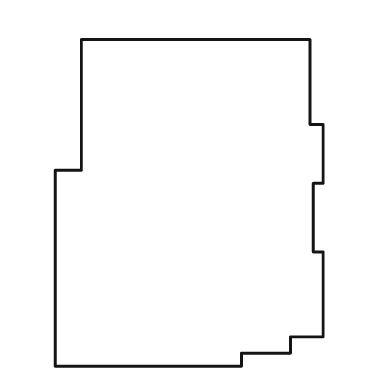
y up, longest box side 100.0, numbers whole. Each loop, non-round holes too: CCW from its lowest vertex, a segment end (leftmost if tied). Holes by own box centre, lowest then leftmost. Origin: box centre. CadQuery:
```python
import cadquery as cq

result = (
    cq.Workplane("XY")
    .moveTo(-41.0, -50.0)
    .lineTo(16.0, -50.0)
    .lineTo(16.0, -46.0)
    .lineTo(31.0, -46.0)
    .lineTo(31.0, -41.0)
    .lineTo(41.0, -41.0)
    .lineTo(41.0, -15.0)
    .lineTo(38.0, -15.0)
    .lineTo(38.0, 6.0)
    .lineTo(41.0, 6.0)
    .lineTo(41.0, 24.0)
    .lineTo(37.0, 24.0)
    .lineTo(37.0, 50.0)
    .lineTo(-33.0, 50.0)
    .lineTo(-33.0, 10.0)
    .lineTo(-41.0, 10.0)
    .close()
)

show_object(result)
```